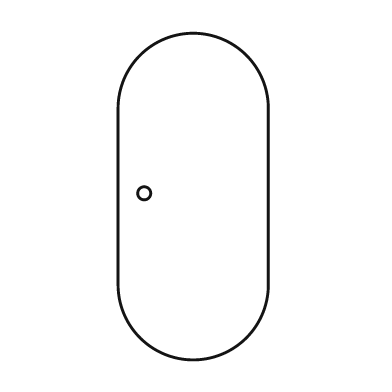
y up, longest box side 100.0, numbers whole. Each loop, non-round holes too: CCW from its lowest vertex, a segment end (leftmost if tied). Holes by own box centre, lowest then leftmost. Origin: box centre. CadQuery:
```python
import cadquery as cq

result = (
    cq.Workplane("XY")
    .moveTo(-23.0, -27.0)
    .threePointArc((0.0, -50.0), (23.0, -27.0))
    .lineTo(23.0, 27.0)
    .threePointArc((0.0, 50.0), (-23.0, 27.0))
    .close()
    .moveTo(-15.0, 1.0)
    .circle(2.0)
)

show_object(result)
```